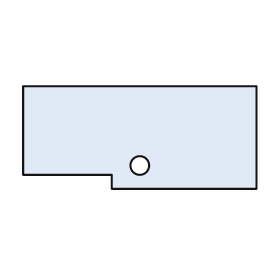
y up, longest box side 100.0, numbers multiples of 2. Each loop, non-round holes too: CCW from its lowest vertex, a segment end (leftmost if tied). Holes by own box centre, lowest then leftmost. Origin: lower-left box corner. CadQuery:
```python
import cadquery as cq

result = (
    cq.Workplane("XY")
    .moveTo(38.0, 0.0)
    .lineTo(100.0, 0.0)
    .lineTo(100.0, 44.0)
    .lineTo(0.0, 44.0)
    .lineTo(0.0, 6.0)
    .lineTo(38.0, 6.0)
    .close()
    .moveTo(50.0, 10.0)
    .circle(4.0)
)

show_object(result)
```